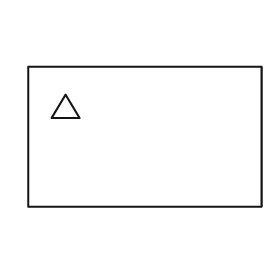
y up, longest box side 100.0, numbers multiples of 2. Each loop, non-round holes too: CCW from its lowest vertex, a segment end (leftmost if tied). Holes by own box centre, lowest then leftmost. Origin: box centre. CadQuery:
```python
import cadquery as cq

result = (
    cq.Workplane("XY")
    .moveTo(-50.0, -30.0)
    .lineTo(50.0, -30.0)
    .lineTo(50.0, 30.0)
    .lineTo(-50.0, 30.0)
    .close()
    .moveTo(-40.0, 8.0)
    .lineTo(-28.0, 8.0)
    .lineTo(-34.0, 18.0)
    .close()
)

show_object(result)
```